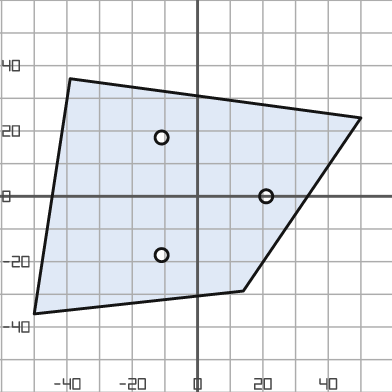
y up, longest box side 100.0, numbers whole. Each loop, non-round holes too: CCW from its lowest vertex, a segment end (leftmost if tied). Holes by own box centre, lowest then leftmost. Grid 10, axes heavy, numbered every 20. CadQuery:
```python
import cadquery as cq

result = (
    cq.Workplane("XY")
    .moveTo(-50.0, -36.0)
    .lineTo(14.0, -29.0)
    .lineTo(50.0, 24.0)
    .lineTo(-39.0, 36.0)
    .close()
    .moveTo(-11.0, -18.0)
    .circle(2.0)
    .moveTo(21.0, 0.0)
    .circle(2.0)
    .moveTo(-11.0, 18.0)
    .circle(2.0)
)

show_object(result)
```